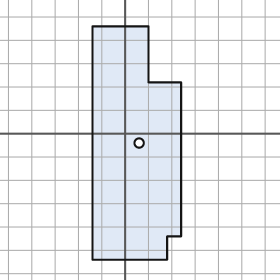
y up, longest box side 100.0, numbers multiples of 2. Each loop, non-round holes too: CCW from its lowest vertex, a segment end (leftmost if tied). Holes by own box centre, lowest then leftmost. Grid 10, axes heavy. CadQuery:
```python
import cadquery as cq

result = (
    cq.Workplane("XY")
    .moveTo(-14.0, -54.0)
    .lineTo(18.0, -54.0)
    .lineTo(18.0, -44.0)
    .lineTo(24.0, -44.0)
    .lineTo(24.0, 22.0)
    .lineTo(10.0, 22.0)
    .lineTo(10.0, 46.0)
    .lineTo(-14.0, 46.0)
    .close()
    .moveTo(6.0, -4.0)
    .circle(2.0)
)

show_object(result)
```